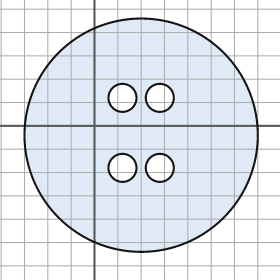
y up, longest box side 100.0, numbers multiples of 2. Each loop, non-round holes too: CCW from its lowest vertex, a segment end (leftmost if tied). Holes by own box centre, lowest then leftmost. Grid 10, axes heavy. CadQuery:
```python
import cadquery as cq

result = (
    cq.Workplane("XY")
    .moveTo(20.0, -4.0)
    .circle(50.0)
    .moveTo(12.0, -18.0)
    .circle(6.0)
    .moveTo(28.0, -18.0)
    .circle(6.0)
    .moveTo(12.0, 12.0)
    .circle(6.0)
    .moveTo(28.0, 12.0)
    .circle(6.0)
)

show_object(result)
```